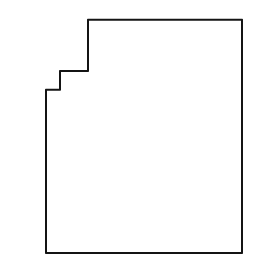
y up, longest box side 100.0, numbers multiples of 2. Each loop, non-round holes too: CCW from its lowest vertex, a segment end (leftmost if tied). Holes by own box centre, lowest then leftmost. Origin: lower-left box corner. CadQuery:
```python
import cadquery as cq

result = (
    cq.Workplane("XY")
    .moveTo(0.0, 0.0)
    .lineTo(84.0, 0.0)
    .lineTo(84.0, 100.0)
    .lineTo(18.0, 100.0)
    .lineTo(18.0, 78.0)
    .lineTo(6.0, 78.0)
    .lineTo(6.0, 70.0)
    .lineTo(0.0, 70.0)
    .close()
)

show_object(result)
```